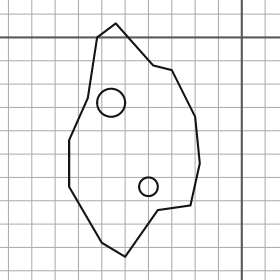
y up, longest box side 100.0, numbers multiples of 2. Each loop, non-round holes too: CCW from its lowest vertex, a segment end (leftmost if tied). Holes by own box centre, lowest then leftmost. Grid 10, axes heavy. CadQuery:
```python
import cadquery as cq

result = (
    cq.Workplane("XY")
    .moveTo(-50.0, -94.0)
    .lineTo(-36.0, -74.0)
    .lineTo(-22.0, -72.0)
    .lineTo(-18.0, -54.0)
    .lineTo(-20.0, -34.0)
    .lineTo(-30.0, -14.0)
    .lineTo(-38.0, -12.0)
    .lineTo(-54.0, 6.0)
    .lineTo(-62.0, 0.0)
    .lineTo(-66.0, -26.0)
    .lineTo(-74.0, -44.0)
    .lineTo(-74.0, -64.0)
    .lineTo(-60.0, -88.0)
    .close()
    .moveTo(-40.0, -64.0)
    .circle(4.0)
    .moveTo(-56.0, -28.0)
    .circle(6.0)
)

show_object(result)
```